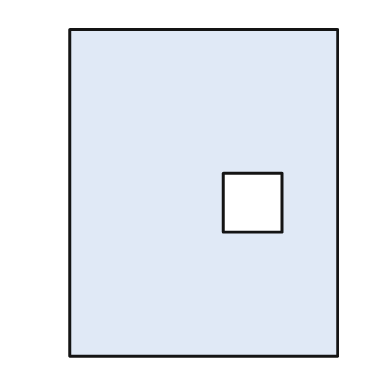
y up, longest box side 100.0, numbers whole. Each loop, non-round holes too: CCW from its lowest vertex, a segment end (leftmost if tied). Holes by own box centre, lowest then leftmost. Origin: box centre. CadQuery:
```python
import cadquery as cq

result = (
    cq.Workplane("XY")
    .moveTo(-41.0, -50.0)
    .lineTo(41.0, -50.0)
    .lineTo(41.0, 50.0)
    .lineTo(-41.0, 50.0)
    .close()
    .moveTo(6.0, -12.0)
    .lineTo(24.0, -12.0)
    .lineTo(24.0, 6.0)
    .lineTo(6.0, 6.0)
    .close()
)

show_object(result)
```